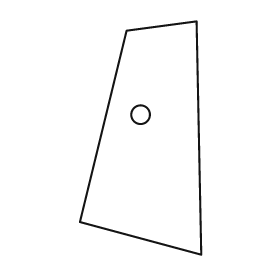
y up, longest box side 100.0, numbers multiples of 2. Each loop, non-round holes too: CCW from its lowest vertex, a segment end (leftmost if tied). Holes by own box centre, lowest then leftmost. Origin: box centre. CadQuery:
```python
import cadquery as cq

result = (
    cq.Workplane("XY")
    .moveTo(26.0, -50.0)
    .lineTo(24.0, 50.0)
    .lineTo(-6.0, 46.0)
    .lineTo(-26.0, -36.0)
    .close()
    .moveTo(0.0, 10.0)
    .circle(4.0)
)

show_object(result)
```